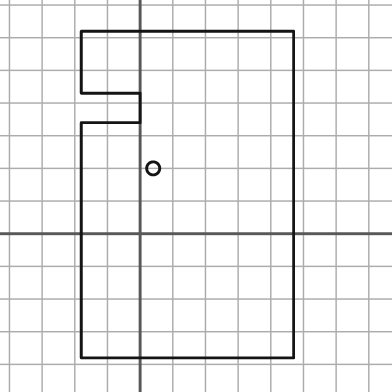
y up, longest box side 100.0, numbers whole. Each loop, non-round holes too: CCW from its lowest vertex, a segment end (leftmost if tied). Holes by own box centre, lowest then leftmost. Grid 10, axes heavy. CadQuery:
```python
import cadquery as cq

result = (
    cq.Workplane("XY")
    .moveTo(-18.0, -38.0)
    .lineTo(47.0, -38.0)
    .lineTo(47.0, 62.0)
    .lineTo(-18.0, 62.0)
    .lineTo(-18.0, 43.0)
    .lineTo(0.0, 43.0)
    .lineTo(0.0, 34.0)
    .lineTo(-18.0, 34.0)
    .close()
    .moveTo(4.0, 20.0)
    .circle(2.0)
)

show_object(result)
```